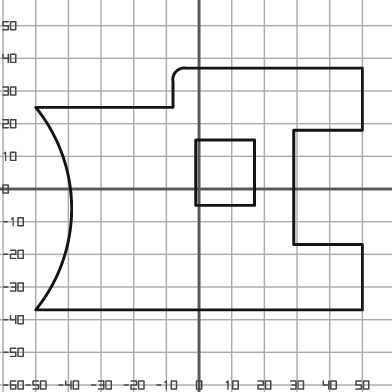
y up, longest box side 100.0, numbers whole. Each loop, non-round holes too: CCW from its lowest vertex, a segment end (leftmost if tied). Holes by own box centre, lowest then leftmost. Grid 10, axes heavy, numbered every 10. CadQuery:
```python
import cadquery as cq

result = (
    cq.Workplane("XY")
    .moveTo(-50.0, -37.0)
    .lineTo(50.0, -37.0)
    .lineTo(50.0, -17.0)
    .lineTo(29.0, -17.0)
    .lineTo(29.0, 18.0)
    .lineTo(50.0, 18.0)
    .lineTo(50.0, 37.0)
    .lineTo(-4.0, 37.0)
    .threePointArc((-7.0, 36.0), (-8.0, 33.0))
    .lineTo(-8.0, 25.0)
    .lineTo(-50.0, 25.0)
    .threePointArc((-39.0, -6.0), (-50.0, -37.0))
    .close()
    .moveTo(-1.0, -5.0)
    .lineTo(17.0, -5.0)
    .lineTo(17.0, 15.0)
    .lineTo(-1.0, 15.0)
    .close()
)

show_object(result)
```